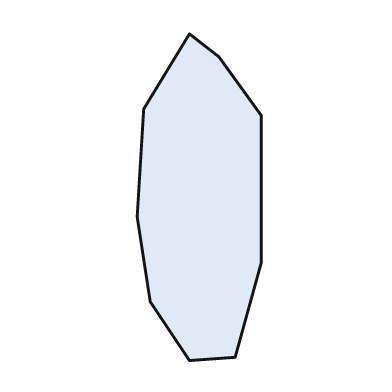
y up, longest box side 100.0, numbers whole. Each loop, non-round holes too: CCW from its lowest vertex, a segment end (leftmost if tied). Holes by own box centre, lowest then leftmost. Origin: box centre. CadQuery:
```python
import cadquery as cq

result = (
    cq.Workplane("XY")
    .moveTo(-3.0, -50.0)
    .lineTo(11.0, -49.0)
    .lineTo(19.0, -20.0)
    .lineTo(19.0, 25.0)
    .lineTo(6.0, 43.0)
    .lineTo(-3.0, 50.0)
    .lineTo(-17.0, 27.0)
    .lineTo(-19.0, -6.0)
    .lineTo(-15.0, -32.0)
    .close()
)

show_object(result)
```